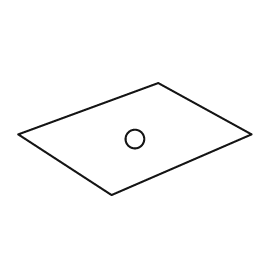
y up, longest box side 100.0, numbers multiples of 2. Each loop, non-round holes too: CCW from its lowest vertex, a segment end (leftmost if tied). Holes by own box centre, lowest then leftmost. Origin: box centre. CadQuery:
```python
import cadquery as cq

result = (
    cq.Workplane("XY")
    .moveTo(-10.0, -24.0)
    .lineTo(50.0, 2.0)
    .lineTo(10.0, 24.0)
    .lineTo(-50.0, 2.0)
    .close()
    .moveTo(0.0, 0.0)
    .circle(4.0)
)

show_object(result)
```